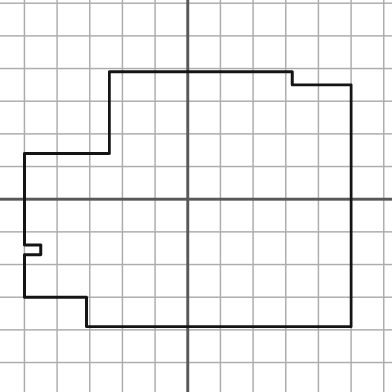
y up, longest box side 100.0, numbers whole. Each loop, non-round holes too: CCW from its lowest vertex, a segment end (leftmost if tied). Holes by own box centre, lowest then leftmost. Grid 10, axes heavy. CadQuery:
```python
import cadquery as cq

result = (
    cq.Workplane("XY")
    .moveTo(-31.0, -39.0)
    .lineTo(50.0, -39.0)
    .lineTo(50.0, 35.0)
    .lineTo(32.0, 35.0)
    .lineTo(32.0, 39.0)
    .lineTo(-24.0, 39.0)
    .lineTo(-24.0, 14.0)
    .lineTo(-50.0, 14.0)
    .lineTo(-50.0, -14.0)
    .lineTo(-45.0, -14.0)
    .lineTo(-45.0, -17.0)
    .lineTo(-50.0, -17.0)
    .lineTo(-50.0, -30.0)
    .lineTo(-31.0, -30.0)
    .close()
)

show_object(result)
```